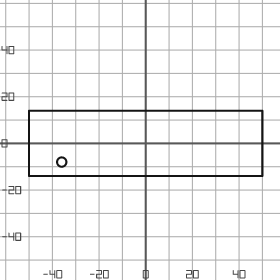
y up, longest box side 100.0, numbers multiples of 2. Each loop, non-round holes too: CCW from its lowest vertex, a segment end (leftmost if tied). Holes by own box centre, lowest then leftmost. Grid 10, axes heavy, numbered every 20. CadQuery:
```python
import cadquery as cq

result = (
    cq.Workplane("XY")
    .moveTo(-50.0, -14.0)
    .lineTo(50.0, -14.0)
    .lineTo(50.0, 14.0)
    .lineTo(-50.0, 14.0)
    .close()
    .moveTo(-36.0, -8.0)
    .circle(2.0)
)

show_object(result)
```